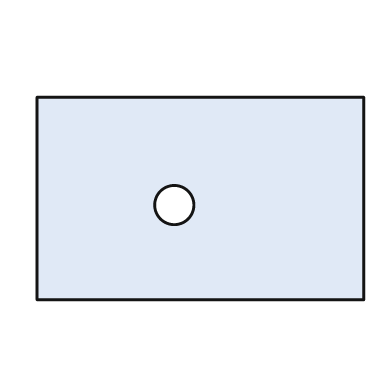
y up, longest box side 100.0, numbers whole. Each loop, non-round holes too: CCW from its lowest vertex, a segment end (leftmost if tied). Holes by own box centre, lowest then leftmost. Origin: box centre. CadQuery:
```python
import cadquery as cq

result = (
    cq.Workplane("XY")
    .moveTo(-50.0, -31.0)
    .lineTo(50.0, -31.0)
    .lineTo(50.0, 31.0)
    .lineTo(-50.0, 31.0)
    .close()
    .moveTo(-8.0, -2.0)
    .circle(6.0)
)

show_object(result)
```